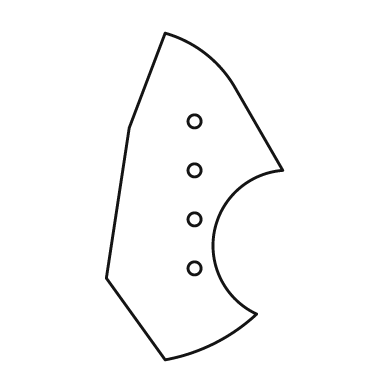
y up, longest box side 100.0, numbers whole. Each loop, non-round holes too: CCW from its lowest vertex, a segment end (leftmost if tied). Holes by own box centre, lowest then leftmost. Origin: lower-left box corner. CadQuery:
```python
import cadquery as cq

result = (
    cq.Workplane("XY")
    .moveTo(18.0, 0.0)
    .threePointArc((33.0, 5.0), (46.0, 14.0))
    .threePointArc((33.0, 39.0), (54.0, 58.0))
    .lineTo(39.0, 84.0)
    .threePointArc((30.0, 94.0), (18.0, 100.0))
    .lineTo(7.0, 71.0)
    .lineTo(0.0, 25.0)
    .close()
    .moveTo(27.0, 28.0)
    .circle(2.0)
    .moveTo(27.0, 43.0)
    .circle(2.0)
    .moveTo(27.0, 58.0)
    .circle(2.0)
    .moveTo(27.0, 73.0)
    .circle(2.0)
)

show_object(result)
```